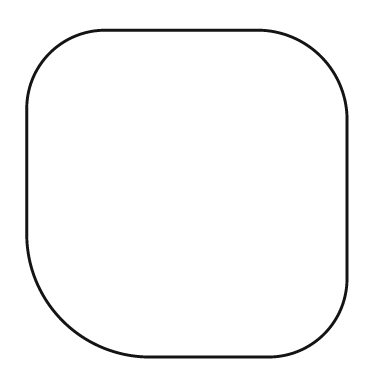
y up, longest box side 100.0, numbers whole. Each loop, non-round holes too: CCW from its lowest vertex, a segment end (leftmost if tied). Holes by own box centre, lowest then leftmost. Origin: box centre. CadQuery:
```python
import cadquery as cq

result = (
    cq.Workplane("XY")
    .moveTo(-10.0, -50.0)
    .lineTo(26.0, -50.0)
    .threePointArc((42.0, -43.0), (49.0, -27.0))
    .lineTo(49.0, 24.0)
    .threePointArc((41.0, 42.0), (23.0, 50.0))
    .lineTo(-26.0, 50.0)
    .threePointArc((-42.0, 43.0), (-49.0, 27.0))
    .lineTo(-49.0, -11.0)
    .threePointArc((-38.0, -39.0), (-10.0, -50.0))
    .close()
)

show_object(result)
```